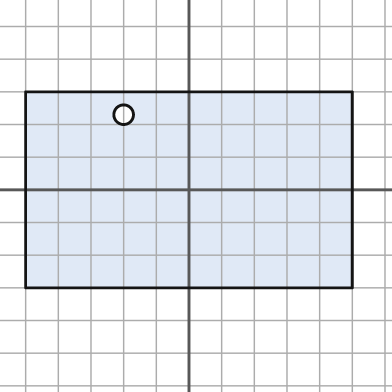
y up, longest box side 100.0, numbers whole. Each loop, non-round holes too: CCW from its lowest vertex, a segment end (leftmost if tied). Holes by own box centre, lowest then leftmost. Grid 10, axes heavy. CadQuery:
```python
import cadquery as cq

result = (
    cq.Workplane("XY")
    .moveTo(-50.0, -30.0)
    .lineTo(50.0, -30.0)
    .lineTo(50.0, 30.0)
    .lineTo(-50.0, 30.0)
    .close()
    .moveTo(-20.0, 23.0)
    .circle(3.0)
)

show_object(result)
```